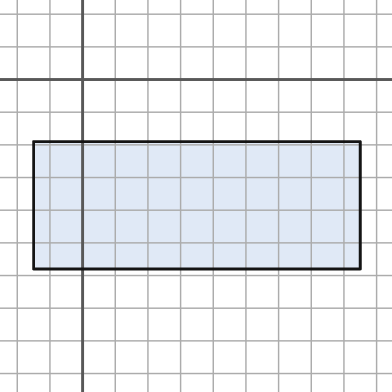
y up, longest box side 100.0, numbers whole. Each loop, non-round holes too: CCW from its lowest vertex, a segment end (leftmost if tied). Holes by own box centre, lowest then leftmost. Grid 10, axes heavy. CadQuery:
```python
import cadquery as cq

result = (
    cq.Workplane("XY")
    .moveTo(-15.0, -58.0)
    .lineTo(85.0, -58.0)
    .lineTo(85.0, -19.0)
    .lineTo(-15.0, -19.0)
    .close()
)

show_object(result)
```